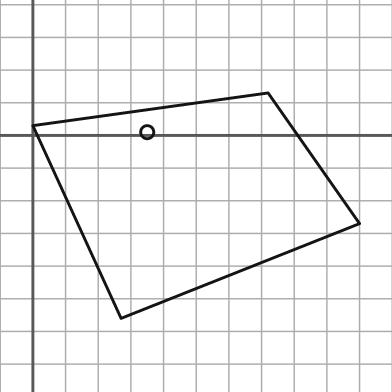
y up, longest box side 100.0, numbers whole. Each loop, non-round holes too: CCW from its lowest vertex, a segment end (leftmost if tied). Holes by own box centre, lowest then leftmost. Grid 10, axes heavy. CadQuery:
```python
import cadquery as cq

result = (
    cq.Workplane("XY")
    .moveTo(27.0, -56.0)
    .lineTo(100.0, -27.0)
    .lineTo(72.0, 13.0)
    .lineTo(0.0, 3.0)
    .close()
    .moveTo(35.0, 1.0)
    .circle(2.0)
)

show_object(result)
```